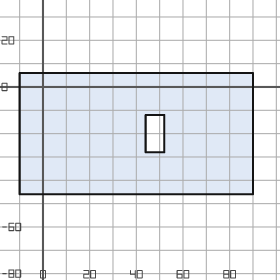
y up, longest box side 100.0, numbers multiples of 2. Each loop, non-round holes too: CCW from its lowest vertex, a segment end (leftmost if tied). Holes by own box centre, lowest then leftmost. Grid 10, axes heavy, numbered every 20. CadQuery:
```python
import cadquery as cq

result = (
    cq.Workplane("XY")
    .moveTo(-10.0, -46.0)
    .lineTo(90.0, -46.0)
    .lineTo(90.0, 6.0)
    .lineTo(-10.0, 6.0)
    .close()
    .moveTo(44.0, -28.0)
    .lineTo(52.0, -28.0)
    .lineTo(52.0, -12.0)
    .lineTo(44.0, -12.0)
    .close()
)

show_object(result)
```